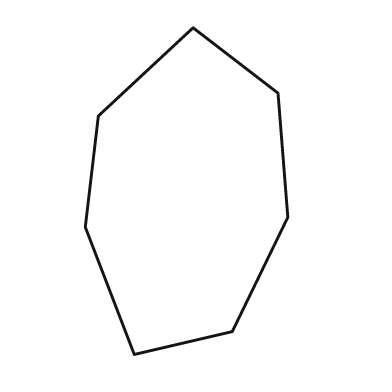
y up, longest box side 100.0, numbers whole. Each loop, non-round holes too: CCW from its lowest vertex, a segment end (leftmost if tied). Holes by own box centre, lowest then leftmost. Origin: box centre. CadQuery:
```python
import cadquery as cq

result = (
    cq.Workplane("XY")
    .moveTo(-16.0, -50.0)
    .lineTo(14.0, -43.0)
    .lineTo(31.0, -8.0)
    .lineTo(28.0, 30.0)
    .lineTo(2.0, 50.0)
    .lineTo(-27.0, 23.0)
    .lineTo(-31.0, -11.0)
    .close()
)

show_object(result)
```